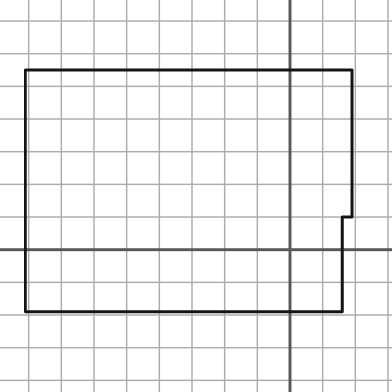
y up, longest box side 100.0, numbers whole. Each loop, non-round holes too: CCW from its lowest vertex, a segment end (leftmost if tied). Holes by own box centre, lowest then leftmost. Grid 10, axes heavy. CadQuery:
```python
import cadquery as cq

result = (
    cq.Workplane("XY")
    .moveTo(-81.0, -19.0)
    .lineTo(16.0, -19.0)
    .lineTo(16.0, 10.0)
    .lineTo(19.0, 10.0)
    .lineTo(19.0, 55.0)
    .lineTo(-81.0, 55.0)
    .close()
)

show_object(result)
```